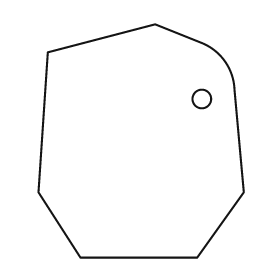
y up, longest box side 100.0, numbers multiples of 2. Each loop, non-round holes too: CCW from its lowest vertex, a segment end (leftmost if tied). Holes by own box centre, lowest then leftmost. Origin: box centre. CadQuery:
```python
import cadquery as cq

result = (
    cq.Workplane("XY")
    .moveTo(-26.0, -50.0)
    .lineTo(24.0, -50.0)
    .lineTo(44.0, -22.0)
    .lineTo(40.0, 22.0)
    .threePointArc((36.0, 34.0), (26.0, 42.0))
    .lineTo(6.0, 50.0)
    .lineTo(-40.0, 38.0)
    .lineTo(-44.0, -22.0)
    .close()
    .moveTo(26.0, 18.0)
    .circle(4.0)
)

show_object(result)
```